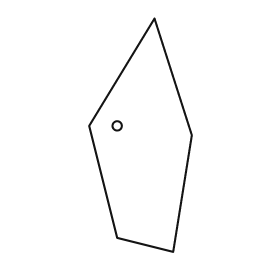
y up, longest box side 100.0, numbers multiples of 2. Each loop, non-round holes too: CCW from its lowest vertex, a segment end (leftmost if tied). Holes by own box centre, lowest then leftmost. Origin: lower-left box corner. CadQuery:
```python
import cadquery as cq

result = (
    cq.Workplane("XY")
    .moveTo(36.0, 0.0)
    .lineTo(44.0, 50.0)
    .lineTo(28.0, 100.0)
    .lineTo(0.0, 54.0)
    .lineTo(12.0, 6.0)
    .close()
    .moveTo(12.0, 54.0)
    .circle(2.0)
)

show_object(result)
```